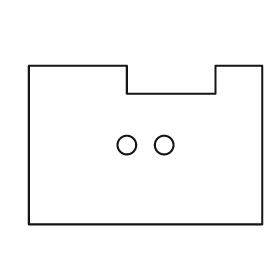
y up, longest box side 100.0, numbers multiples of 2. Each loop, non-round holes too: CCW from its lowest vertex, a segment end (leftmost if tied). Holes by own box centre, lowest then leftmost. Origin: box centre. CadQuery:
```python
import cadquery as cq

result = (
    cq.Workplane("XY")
    .moveTo(-50.0, -34.0)
    .lineTo(50.0, -34.0)
    .lineTo(50.0, 34.0)
    .lineTo(30.0, 34.0)
    .lineTo(30.0, 22.0)
    .lineTo(-8.0, 22.0)
    .lineTo(-8.0, 34.0)
    .lineTo(-50.0, 34.0)
    .close()
    .moveTo(-8.0, 0.0)
    .circle(4.0)
    .moveTo(8.0, 0.0)
    .circle(4.0)
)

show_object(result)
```